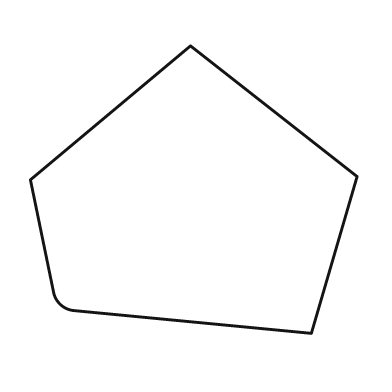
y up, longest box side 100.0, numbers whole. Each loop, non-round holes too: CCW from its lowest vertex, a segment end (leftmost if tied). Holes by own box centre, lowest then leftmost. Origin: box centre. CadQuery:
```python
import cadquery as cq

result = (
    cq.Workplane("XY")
    .moveTo(36.0, -44.0)
    .lineTo(50.0, 4.0)
    .lineTo(-1.0, 44.0)
    .lineTo(-50.0, 3.0)
    .lineTo(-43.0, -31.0)
    .threePointArc((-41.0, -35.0), (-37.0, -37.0))
    .close()
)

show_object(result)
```